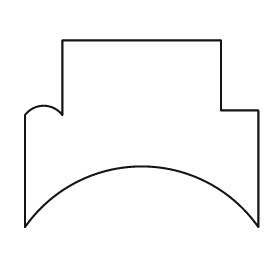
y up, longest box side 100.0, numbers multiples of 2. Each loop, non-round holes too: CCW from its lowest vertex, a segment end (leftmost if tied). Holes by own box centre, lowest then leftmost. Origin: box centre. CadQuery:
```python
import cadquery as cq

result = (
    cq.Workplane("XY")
    .moveTo(-50.0, -40.0)
    .threePointArc((0.0, -14.0), (50.0, -40.0))
    .lineTo(50.0, 10.0)
    .lineTo(34.0, 10.0)
    .lineTo(34.0, 40.0)
    .lineTo(-34.0, 40.0)
    .lineTo(-34.0, 8.0)
    .threePointArc((-42.0, 12.0), (-50.0, 8.0))
    .close()
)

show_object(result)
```